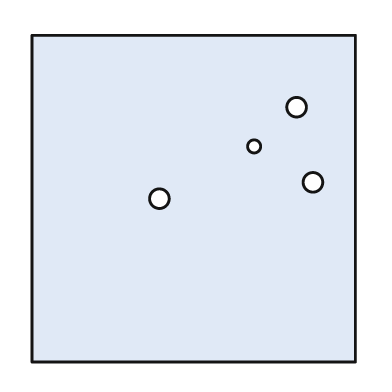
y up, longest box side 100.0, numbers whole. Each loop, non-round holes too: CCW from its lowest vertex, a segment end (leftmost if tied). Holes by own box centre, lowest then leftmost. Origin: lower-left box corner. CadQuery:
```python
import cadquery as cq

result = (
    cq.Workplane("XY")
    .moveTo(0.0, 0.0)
    .lineTo(99.0, 0.0)
    .lineTo(99.0, 100.0)
    .lineTo(0.0, 100.0)
    .close()
    .moveTo(39.0, 50.0)
    .circle(3.0)
    .moveTo(86.0, 55.0)
    .circle(3.0)
    .moveTo(68.0, 66.0)
    .circle(2.0)
    .moveTo(81.0, 78.0)
    .circle(3.0)
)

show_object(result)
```